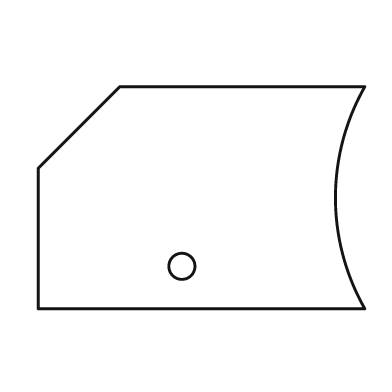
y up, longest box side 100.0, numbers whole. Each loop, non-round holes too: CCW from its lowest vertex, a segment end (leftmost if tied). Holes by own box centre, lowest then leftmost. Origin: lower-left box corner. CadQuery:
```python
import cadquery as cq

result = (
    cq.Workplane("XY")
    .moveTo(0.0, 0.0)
    .lineTo(100.0, 0.0)
    .threePointArc((91.0, 34.0), (100.0, 68.0))
    .lineTo(25.0, 68.0)
    .lineTo(0.0, 43.0)
    .close()
    .moveTo(44.0, 13.0)
    .circle(4.0)
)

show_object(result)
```